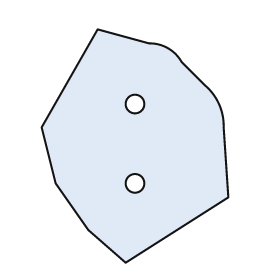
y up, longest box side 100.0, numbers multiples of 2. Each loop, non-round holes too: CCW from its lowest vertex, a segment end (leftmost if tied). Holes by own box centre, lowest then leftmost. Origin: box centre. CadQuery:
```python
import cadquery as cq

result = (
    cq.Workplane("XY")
    .moveTo(-4.0, -50.0)
    .lineTo(40.0, -22.0)
    .lineTo(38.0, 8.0)
    .threePointArc((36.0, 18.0), (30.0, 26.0))
    .lineTo(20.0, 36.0)
    .threePointArc((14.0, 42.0), (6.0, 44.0))
    .lineTo(-16.0, 50.0)
    .lineTo(-40.0, 8.0)
    .lineTo(-34.0, -16.0)
    .lineTo(-20.0, -36.0)
    .close()
    .moveTo(0.0, -16.0)
    .circle(4.0)
    .moveTo(0.0, 18.0)
    .circle(4.0)
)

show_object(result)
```